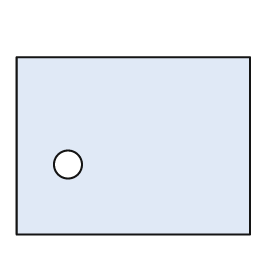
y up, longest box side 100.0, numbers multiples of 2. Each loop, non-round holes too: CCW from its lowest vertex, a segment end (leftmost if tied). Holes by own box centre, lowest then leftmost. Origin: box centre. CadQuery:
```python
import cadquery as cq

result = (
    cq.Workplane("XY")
    .moveTo(-50.0, -38.0)
    .lineTo(50.0, -38.0)
    .lineTo(50.0, 38.0)
    .lineTo(-50.0, 38.0)
    .close()
    .moveTo(-28.0, -8.0)
    .circle(6.0)
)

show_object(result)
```